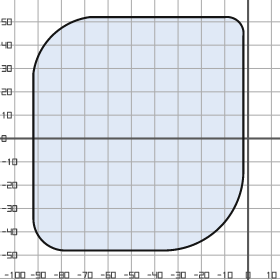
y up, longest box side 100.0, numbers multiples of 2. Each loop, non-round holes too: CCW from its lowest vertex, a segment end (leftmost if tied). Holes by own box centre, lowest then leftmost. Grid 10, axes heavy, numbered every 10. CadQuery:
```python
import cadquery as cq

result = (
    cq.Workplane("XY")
    .moveTo(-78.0, -48.0)
    .lineTo(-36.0, -48.0)
    .threePointArc((-12.0, -38.0), (-2.0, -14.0))
    .lineTo(-2.0, 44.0)
    .threePointArc((-4.0, 50.0), (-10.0, 52.0))
    .lineTo(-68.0, 52.0)
    .threePointArc((-84.0, 44.0), (-92.0, 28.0))
    .lineTo(-92.0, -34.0)
    .threePointArc((-88.0, -44.0), (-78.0, -48.0))
    .close()
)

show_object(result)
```